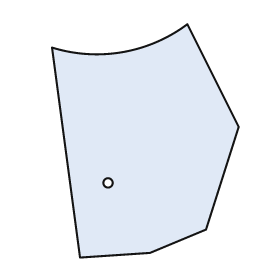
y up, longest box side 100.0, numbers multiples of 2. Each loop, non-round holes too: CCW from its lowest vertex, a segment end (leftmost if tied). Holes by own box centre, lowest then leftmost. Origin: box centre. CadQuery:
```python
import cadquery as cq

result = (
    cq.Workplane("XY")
    .moveTo(-28.0, -50.0)
    .lineTo(2.0, -48.0)
    .lineTo(26.0, -38.0)
    .lineTo(40.0, 6.0)
    .lineTo(18.0, 50.0)
    .threePointArc((-10.0, 38.0), (-40.0, 40.0))
    .close()
    .moveTo(-16.0, -18.0)
    .circle(2.0)
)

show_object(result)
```